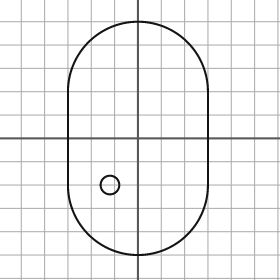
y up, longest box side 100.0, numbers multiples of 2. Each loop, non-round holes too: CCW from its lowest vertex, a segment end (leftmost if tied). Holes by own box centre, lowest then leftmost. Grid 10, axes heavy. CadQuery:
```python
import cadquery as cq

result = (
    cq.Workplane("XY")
    .moveTo(-30.0, -20.0)
    .threePointArc((0.0, -50.0), (30.0, -20.0))
    .lineTo(30.0, 20.0)
    .threePointArc((0.0, 50.0), (-30.0, 20.0))
    .close()
    .moveTo(-12.0, -20.0)
    .circle(4.0)
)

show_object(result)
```